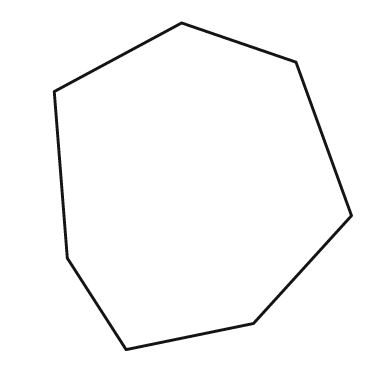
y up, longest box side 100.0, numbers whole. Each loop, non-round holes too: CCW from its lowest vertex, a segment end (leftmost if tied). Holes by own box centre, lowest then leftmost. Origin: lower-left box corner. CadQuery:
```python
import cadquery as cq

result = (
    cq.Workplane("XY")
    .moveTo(22.0, 0.0)
    .lineTo(61.0, 8.0)
    .lineTo(91.0, 41.0)
    .lineTo(74.0, 88.0)
    .lineTo(39.0, 100.0)
    .lineTo(0.0, 79.0)
    .lineTo(4.0, 28.0)
    .close()
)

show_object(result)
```